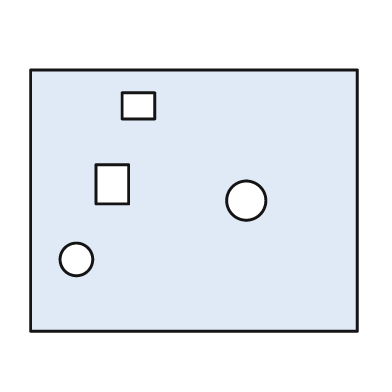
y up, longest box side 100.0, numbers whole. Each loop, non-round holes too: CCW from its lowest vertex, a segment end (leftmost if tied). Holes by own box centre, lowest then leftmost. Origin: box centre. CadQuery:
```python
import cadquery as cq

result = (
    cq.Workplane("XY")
    .moveTo(-50.0, -40.0)
    .lineTo(50.0, -40.0)
    .lineTo(50.0, 40.0)
    .lineTo(-50.0, 40.0)
    .close()
    .moveTo(-36.0, -18.0)
    .circle(5.0)
    .moveTo(16.0, 0.0)
    .circle(6.0)
    .moveTo(-30.0, -1.0)
    .lineTo(-20.0, -1.0)
    .lineTo(-20.0, 11.0)
    .lineTo(-30.0, 11.0)
    .close()
    .moveTo(-22.0, 25.0)
    .lineTo(-12.0, 25.0)
    .lineTo(-12.0, 33.0)
    .lineTo(-22.0, 33.0)
    .close()
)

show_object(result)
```